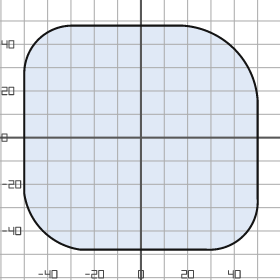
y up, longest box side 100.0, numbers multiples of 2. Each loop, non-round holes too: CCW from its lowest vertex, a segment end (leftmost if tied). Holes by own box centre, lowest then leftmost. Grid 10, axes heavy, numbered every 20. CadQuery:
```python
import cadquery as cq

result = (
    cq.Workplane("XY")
    .moveTo(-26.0, -48.0)
    .lineTo(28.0, -48.0)
    .threePointArc((44.0, -42.0), (50.0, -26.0))
    .lineTo(50.0, 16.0)
    .threePointArc((40.0, 38.0), (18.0, 48.0))
    .lineTo(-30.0, 48.0)
    .threePointArc((-44.0, 42.0), (-50.0, 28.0))
    .lineTo(-50.0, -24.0)
    .threePointArc((-42.0, -40.0), (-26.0, -48.0))
    .close()
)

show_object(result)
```